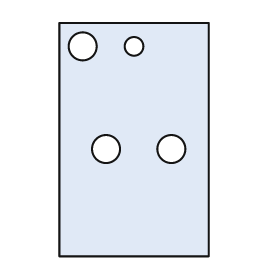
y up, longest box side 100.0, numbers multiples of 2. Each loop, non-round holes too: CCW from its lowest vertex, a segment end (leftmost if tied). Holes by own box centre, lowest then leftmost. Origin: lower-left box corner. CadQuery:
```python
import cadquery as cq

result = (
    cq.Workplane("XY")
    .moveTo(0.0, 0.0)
    .lineTo(64.0, 0.0)
    .lineTo(64.0, 100.0)
    .lineTo(0.0, 100.0)
    .close()
    .moveTo(20.0, 46.0)
    .circle(6.0)
    .moveTo(48.0, 46.0)
    .circle(6.0)
    .moveTo(10.0, 90.0)
    .circle(6.0)
    .moveTo(32.0, 90.0)
    .circle(4.0)
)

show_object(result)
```